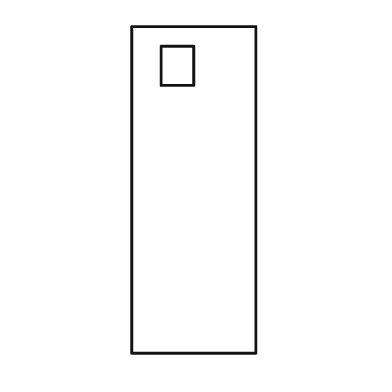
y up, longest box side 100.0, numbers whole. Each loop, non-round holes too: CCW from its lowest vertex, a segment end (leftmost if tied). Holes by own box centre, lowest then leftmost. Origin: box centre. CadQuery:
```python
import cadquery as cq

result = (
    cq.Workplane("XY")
    .moveTo(-19.0, -50.0)
    .lineTo(19.0, -50.0)
    .lineTo(19.0, 50.0)
    .lineTo(-19.0, 50.0)
    .close()
    .moveTo(-10.0, 32.0)
    .lineTo(0.0, 32.0)
    .lineTo(0.0, 44.0)
    .lineTo(-10.0, 44.0)
    .close()
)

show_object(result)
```